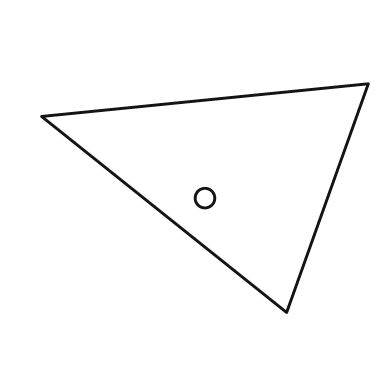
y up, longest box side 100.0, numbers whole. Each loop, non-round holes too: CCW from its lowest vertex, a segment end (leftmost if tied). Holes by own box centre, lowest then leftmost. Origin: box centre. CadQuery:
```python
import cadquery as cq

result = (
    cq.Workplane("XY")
    .moveTo(25.0, -35.0)
    .lineTo(50.0, 35.0)
    .lineTo(-50.0, 25.0)
    .close()
    .moveTo(0.0, 0.0)
    .circle(3.0)
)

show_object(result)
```